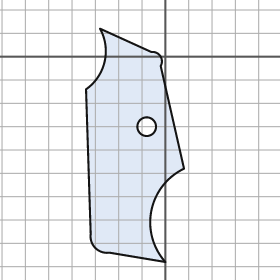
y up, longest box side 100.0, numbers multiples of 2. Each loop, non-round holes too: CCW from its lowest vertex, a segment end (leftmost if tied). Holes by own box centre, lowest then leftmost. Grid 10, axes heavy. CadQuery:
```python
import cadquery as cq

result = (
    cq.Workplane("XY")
    .moveTo(0.0, -88.0)
    .threePointArc((-6.0, -66.0), (8.0, -48.0))
    .lineTo(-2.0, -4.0)
    .threePointArc((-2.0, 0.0), (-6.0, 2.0))
    .lineTo(-28.0, 12.0)
    .threePointArc((-26.0, -2.0), (-34.0, -14.0))
    .lineTo(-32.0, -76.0)
    .threePointArc((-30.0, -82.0), (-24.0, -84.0))
    .close()
    .moveTo(-8.0, -30.0)
    .circle(4.0)
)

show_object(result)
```